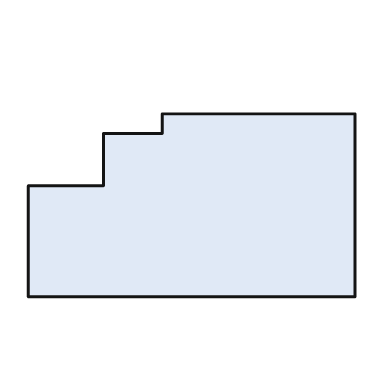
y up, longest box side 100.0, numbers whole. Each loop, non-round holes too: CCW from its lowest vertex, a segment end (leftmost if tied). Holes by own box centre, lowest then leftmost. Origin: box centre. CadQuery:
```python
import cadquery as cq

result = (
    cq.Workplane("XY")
    .moveTo(-50.0, -28.0)
    .lineTo(50.0, -28.0)
    .lineTo(50.0, 28.0)
    .lineTo(-9.0, 28.0)
    .lineTo(-9.0, 22.0)
    .lineTo(-27.0, 22.0)
    .lineTo(-27.0, 6.0)
    .lineTo(-50.0, 6.0)
    .close()
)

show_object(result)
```